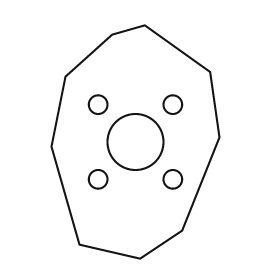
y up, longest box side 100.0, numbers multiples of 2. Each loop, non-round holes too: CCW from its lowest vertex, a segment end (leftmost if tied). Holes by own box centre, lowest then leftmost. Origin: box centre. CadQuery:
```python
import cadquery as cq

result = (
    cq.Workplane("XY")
    .moveTo(2.0, -50.0)
    .lineTo(20.0, -38.0)
    .lineTo(36.0, 2.0)
    .lineTo(32.0, 30.0)
    .lineTo(4.0, 50.0)
    .lineTo(-10.0, 46.0)
    .lineTo(-30.0, 28.0)
    .lineTo(-36.0, -2.0)
    .lineTo(-24.0, -44.0)
    .close()
    .moveTo(-16.0, -16.0)
    .circle(4.0)
    .moveTo(16.0, -16.0)
    .circle(4.0)
    .moveTo(0.0, 0.0)
    .circle(12.0)
    .moveTo(-16.0, 16.0)
    .circle(4.0)
    .moveTo(16.0, 16.0)
    .circle(4.0)
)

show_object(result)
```